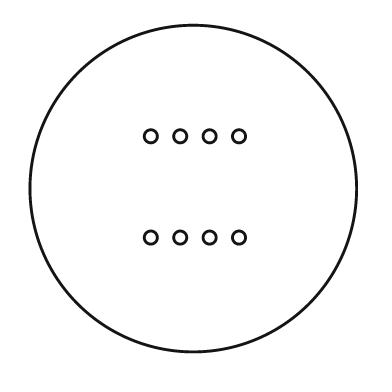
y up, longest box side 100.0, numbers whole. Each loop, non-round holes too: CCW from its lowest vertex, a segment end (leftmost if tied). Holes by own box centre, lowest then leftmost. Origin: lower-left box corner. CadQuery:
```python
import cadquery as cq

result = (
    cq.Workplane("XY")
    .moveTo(50.0, 50.0)
    .circle(50.0)
    .moveTo(37.0, 35.0)
    .circle(2.0)
    .moveTo(46.0, 35.0)
    .circle(2.0)
    .moveTo(55.0, 35.0)
    .circle(2.0)
    .moveTo(64.0, 35.0)
    .circle(2.0)
    .moveTo(37.0, 66.0)
    .circle(2.0)
    .moveTo(46.0, 66.0)
    .circle(2.0)
    .moveTo(55.0, 66.0)
    .circle(2.0)
    .moveTo(64.0, 66.0)
    .circle(2.0)
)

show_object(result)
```